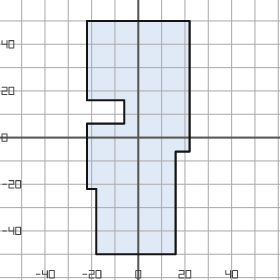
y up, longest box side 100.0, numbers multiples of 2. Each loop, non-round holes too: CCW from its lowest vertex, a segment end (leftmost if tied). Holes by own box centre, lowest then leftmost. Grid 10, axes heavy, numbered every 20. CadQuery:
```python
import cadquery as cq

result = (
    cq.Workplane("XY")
    .moveTo(-18.0, -50.0)
    .lineTo(16.0, -50.0)
    .lineTo(16.0, -6.0)
    .lineTo(22.0, -6.0)
    .lineTo(22.0, 50.0)
    .lineTo(-22.0, 50.0)
    .lineTo(-22.0, 16.0)
    .lineTo(-6.0, 16.0)
    .lineTo(-6.0, 6.0)
    .lineTo(-22.0, 6.0)
    .lineTo(-22.0, -22.0)
    .lineTo(-18.0, -22.0)
    .close()
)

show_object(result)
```